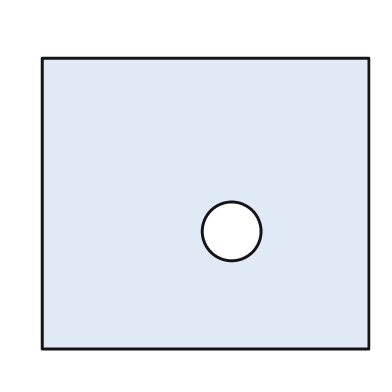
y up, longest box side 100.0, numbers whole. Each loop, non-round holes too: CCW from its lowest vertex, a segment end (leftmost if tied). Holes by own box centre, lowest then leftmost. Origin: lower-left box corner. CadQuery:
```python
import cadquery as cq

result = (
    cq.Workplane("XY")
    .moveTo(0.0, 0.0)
    .lineTo(100.0, 0.0)
    .lineTo(100.0, 89.0)
    .lineTo(0.0, 89.0)
    .close()
    .moveTo(58.0, 36.0)
    .circle(9.0)
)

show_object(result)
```